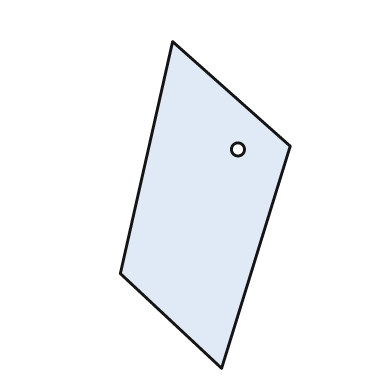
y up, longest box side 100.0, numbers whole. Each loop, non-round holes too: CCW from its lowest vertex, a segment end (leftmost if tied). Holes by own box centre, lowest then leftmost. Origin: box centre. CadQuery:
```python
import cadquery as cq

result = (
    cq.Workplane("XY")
    .moveTo(5.0, -50.0)
    .lineTo(26.0, 18.0)
    .lineTo(-10.0, 50.0)
    .lineTo(-26.0, -21.0)
    .close()
    .moveTo(10.0, 17.0)
    .circle(2.0)
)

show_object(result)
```